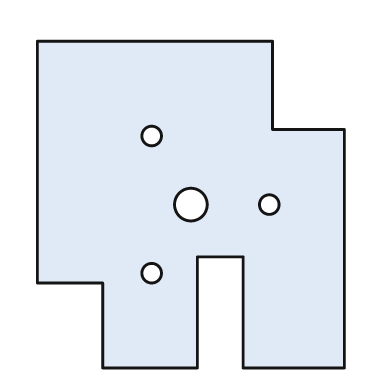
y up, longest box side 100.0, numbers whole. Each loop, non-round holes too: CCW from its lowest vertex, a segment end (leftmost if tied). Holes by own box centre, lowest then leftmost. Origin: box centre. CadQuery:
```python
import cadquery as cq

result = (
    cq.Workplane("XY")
    .moveTo(-27.0, -50.0)
    .lineTo(2.0, -50.0)
    .lineTo(2.0, -16.0)
    .lineTo(16.0, -16.0)
    .lineTo(16.0, -50.0)
    .lineTo(47.0, -50.0)
    .lineTo(47.0, 23.0)
    .lineTo(25.0, 23.0)
    .lineTo(25.0, 50.0)
    .lineTo(-47.0, 50.0)
    .lineTo(-47.0, -24.0)
    .lineTo(-27.0, -24.0)
    .close()
    .moveTo(-12.0, -21.0)
    .circle(3.0)
    .moveTo(0.0, 0.0)
    .circle(5.0)
    .moveTo(24.0, 0.0)
    .circle(3.0)
    .moveTo(-12.0, 21.0)
    .circle(3.0)
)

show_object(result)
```